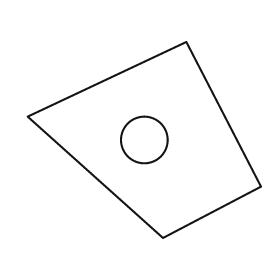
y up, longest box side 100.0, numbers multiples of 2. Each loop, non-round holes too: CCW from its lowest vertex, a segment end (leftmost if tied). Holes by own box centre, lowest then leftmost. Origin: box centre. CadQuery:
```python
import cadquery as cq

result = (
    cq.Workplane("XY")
    .moveTo(8.0, -42.0)
    .lineTo(50.0, -20.0)
    .lineTo(18.0, 42.0)
    .lineTo(-50.0, 10.0)
    .close()
    .moveTo(0.0, 0.0)
    .circle(10.0)
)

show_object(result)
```